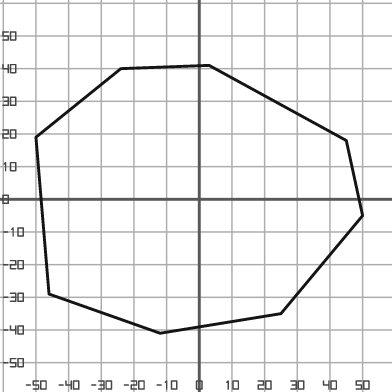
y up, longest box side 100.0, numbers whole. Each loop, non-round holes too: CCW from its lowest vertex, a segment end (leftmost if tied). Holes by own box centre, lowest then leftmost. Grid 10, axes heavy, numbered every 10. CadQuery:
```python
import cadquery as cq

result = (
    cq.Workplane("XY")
    .moveTo(-12.0, -41.0)
    .lineTo(25.0, -35.0)
    .lineTo(50.0, -5.0)
    .lineTo(45.0, 18.0)
    .lineTo(3.0, 41.0)
    .lineTo(-24.0, 40.0)
    .lineTo(-50.0, 19.0)
    .lineTo(-46.0, -29.0)
    .close()
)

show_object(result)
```